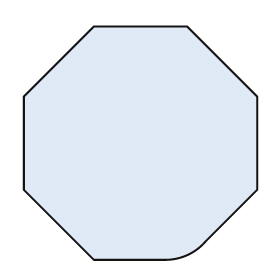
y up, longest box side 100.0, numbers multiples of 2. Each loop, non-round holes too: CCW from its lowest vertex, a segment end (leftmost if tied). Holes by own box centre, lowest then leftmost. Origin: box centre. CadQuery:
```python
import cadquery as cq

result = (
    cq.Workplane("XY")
    .moveTo(-20.0, -50.0)
    .lineTo(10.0, -50.0)
    .threePointArc((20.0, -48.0), (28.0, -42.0))
    .lineTo(50.0, -20.0)
    .lineTo(50.0, 20.0)
    .lineTo(20.0, 50.0)
    .lineTo(-20.0, 50.0)
    .lineTo(-50.0, 20.0)
    .lineTo(-50.0, -20.0)
    .close()
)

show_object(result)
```